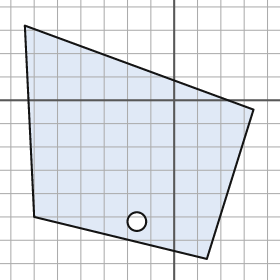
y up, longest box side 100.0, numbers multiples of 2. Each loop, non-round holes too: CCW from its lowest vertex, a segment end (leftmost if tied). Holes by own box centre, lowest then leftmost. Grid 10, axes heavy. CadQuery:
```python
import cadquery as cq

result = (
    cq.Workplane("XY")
    .moveTo(14.0, -68.0)
    .lineTo(34.0, -4.0)
    .lineTo(-64.0, 32.0)
    .lineTo(-60.0, -50.0)
    .close()
    .moveTo(-16.0, -52.0)
    .circle(4.0)
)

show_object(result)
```